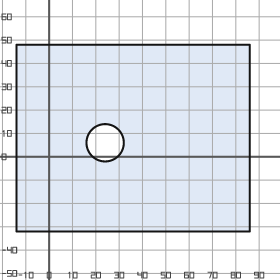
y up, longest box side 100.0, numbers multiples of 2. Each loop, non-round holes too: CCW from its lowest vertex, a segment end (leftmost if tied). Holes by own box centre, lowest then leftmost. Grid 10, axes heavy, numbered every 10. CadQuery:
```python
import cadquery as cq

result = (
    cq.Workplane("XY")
    .moveTo(-14.0, -32.0)
    .lineTo(86.0, -32.0)
    .lineTo(86.0, 48.0)
    .lineTo(-14.0, 48.0)
    .close()
    .moveTo(24.0, 6.0)
    .circle(8.0)
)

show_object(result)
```